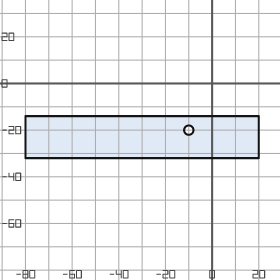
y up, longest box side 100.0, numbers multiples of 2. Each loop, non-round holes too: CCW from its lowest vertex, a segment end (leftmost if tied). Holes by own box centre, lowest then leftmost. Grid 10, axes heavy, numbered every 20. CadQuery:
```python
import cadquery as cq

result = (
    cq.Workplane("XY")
    .moveTo(-80.0, -32.0)
    .lineTo(20.0, -32.0)
    .lineTo(20.0, -14.0)
    .lineTo(-80.0, -14.0)
    .close()
    .moveTo(-10.0, -20.0)
    .circle(2.0)
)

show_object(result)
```